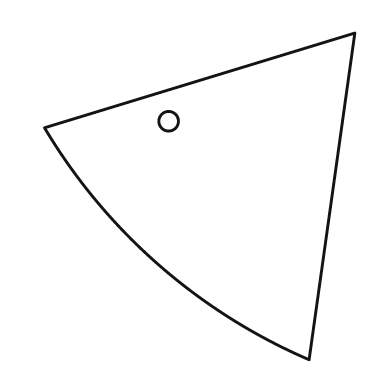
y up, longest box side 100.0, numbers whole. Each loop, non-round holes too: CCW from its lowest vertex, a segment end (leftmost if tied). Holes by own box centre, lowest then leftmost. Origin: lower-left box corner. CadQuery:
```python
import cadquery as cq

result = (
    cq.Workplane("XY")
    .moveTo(81.0, 0.0)
    .lineTo(95.0, 100.0)
    .lineTo(0.0, 71.0)
    .threePointArc((35.0, 29.0), (81.0, 0.0))
    .close()
    .moveTo(38.0, 73.0)
    .circle(3.0)
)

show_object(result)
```